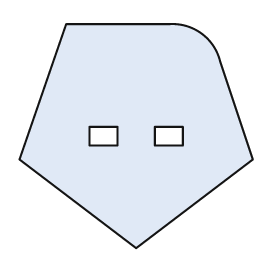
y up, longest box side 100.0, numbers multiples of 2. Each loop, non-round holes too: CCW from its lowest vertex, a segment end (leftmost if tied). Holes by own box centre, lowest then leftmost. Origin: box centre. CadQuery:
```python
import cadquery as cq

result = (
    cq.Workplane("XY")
    .moveTo(0.0, -48.0)
    .lineTo(50.0, -10.0)
    .lineTo(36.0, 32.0)
    .threePointArc((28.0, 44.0), (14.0, 48.0))
    .lineTo(-30.0, 48.0)
    .lineTo(-50.0, -10.0)
    .close()
    .moveTo(-20.0, -4.0)
    .lineTo(-8.0, -4.0)
    .lineTo(-8.0, 4.0)
    .lineTo(-20.0, 4.0)
    .close()
    .moveTo(8.0, -4.0)
    .lineTo(20.0, -4.0)
    .lineTo(20.0, 4.0)
    .lineTo(8.0, 4.0)
    .close()
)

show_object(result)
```